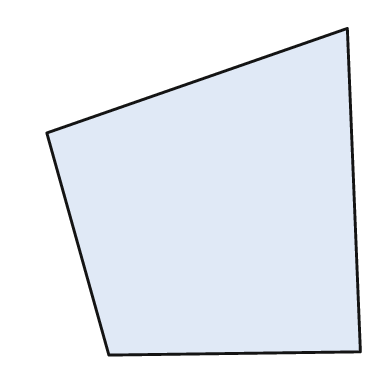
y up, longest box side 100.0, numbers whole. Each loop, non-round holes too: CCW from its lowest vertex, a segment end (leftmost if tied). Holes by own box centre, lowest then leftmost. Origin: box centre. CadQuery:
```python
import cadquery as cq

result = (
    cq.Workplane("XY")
    .moveTo(-29.0, -50.0)
    .lineTo(48.0, -49.0)
    .lineTo(44.0, 50.0)
    .lineTo(-48.0, 18.0)
    .close()
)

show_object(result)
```